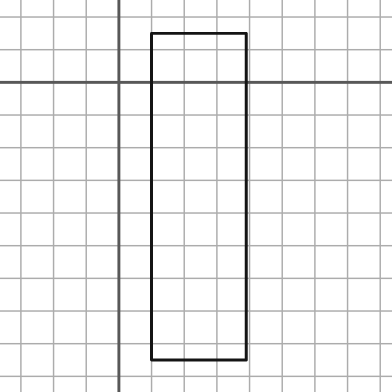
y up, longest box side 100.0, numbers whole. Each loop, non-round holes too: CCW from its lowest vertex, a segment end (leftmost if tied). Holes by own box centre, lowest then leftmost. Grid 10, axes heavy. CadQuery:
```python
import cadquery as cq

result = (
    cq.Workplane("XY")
    .moveTo(10.0, -85.0)
    .lineTo(39.0, -85.0)
    .lineTo(39.0, 15.0)
    .lineTo(10.0, 15.0)
    .close()
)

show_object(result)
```